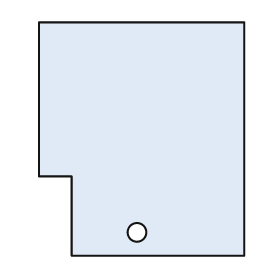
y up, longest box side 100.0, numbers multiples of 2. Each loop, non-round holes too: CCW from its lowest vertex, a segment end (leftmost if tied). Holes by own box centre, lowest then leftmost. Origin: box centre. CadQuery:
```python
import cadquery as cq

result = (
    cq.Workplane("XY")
    .moveTo(-30.0, -50.0)
    .lineTo(44.0, -50.0)
    .lineTo(44.0, 50.0)
    .lineTo(-44.0, 50.0)
    .lineTo(-44.0, -16.0)
    .lineTo(-30.0, -16.0)
    .close()
    .moveTo(-2.0, -40.0)
    .circle(4.0)
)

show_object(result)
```